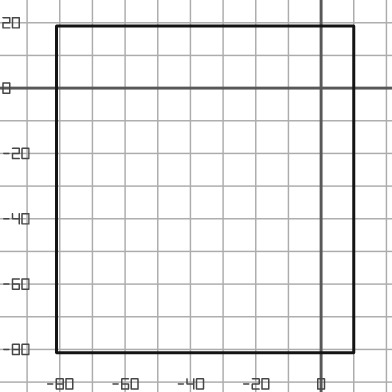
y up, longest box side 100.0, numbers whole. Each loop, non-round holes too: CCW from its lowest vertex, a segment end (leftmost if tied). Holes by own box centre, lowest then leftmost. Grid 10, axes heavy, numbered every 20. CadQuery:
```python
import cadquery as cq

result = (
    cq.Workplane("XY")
    .moveTo(-81.0, -81.0)
    .lineTo(10.0, -81.0)
    .lineTo(10.0, 19.0)
    .lineTo(-81.0, 19.0)
    .close()
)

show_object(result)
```